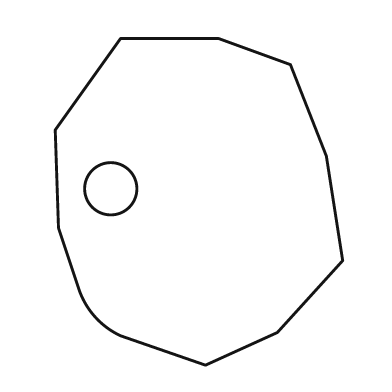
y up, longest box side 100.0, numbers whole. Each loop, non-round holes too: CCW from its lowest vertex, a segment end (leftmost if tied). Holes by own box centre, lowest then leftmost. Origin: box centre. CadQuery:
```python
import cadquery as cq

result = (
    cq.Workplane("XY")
    .moveTo(2.0, -50.0)
    .lineTo(24.0, -40.0)
    .lineTo(44.0, -18.0)
    .lineTo(39.0, 14.0)
    .lineTo(28.0, 42.0)
    .lineTo(6.0, 50.0)
    .lineTo(-24.0, 50.0)
    .lineTo(-44.0, 22.0)
    .lineTo(-43.0, -8.0)
    .lineTo(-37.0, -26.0)
    .threePointArc((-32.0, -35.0), (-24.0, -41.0))
    .close()
    .moveTo(-27.0, 4.0)
    .circle(8.0)
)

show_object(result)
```